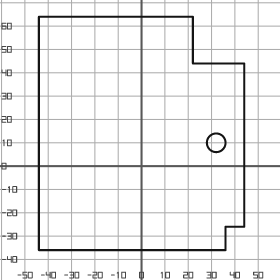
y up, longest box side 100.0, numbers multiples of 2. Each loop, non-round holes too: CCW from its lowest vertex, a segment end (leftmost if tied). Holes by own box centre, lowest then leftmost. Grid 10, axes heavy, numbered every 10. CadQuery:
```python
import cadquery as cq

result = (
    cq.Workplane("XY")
    .moveTo(-44.0, -36.0)
    .lineTo(36.0, -36.0)
    .lineTo(36.0, -26.0)
    .lineTo(44.0, -26.0)
    .lineTo(44.0, 44.0)
    .lineTo(22.0, 44.0)
    .lineTo(22.0, 64.0)
    .lineTo(-44.0, 64.0)
    .close()
    .moveTo(32.0, 10.0)
    .circle(4.0)
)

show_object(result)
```